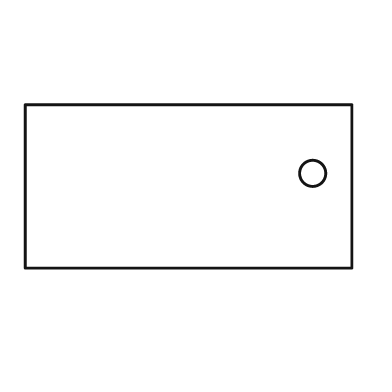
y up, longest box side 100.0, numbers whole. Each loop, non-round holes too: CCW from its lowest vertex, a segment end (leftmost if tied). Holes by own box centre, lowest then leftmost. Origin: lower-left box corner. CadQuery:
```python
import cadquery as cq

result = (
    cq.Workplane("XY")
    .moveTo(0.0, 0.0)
    .lineTo(100.0, 0.0)
    .lineTo(100.0, 50.0)
    .lineTo(0.0, 50.0)
    .close()
    .moveTo(88.0, 29.0)
    .circle(4.0)
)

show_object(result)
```